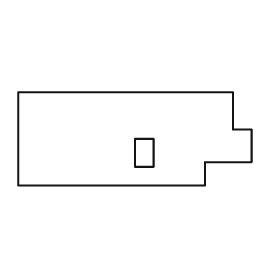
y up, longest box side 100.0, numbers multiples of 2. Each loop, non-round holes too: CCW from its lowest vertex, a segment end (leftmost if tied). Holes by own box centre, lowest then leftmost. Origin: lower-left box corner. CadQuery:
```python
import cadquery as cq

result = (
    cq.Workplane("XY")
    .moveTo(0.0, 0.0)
    .lineTo(80.0, 0.0)
    .lineTo(80.0, 10.0)
    .lineTo(100.0, 10.0)
    .lineTo(100.0, 24.0)
    .lineTo(92.0, 24.0)
    .lineTo(92.0, 40.0)
    .lineTo(0.0, 40.0)
    .close()
    .moveTo(50.0, 8.0)
    .lineTo(58.0, 8.0)
    .lineTo(58.0, 20.0)
    .lineTo(50.0, 20.0)
    .close()
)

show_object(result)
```